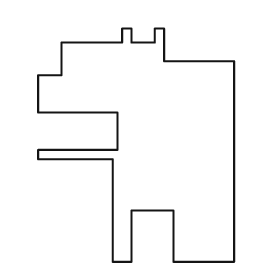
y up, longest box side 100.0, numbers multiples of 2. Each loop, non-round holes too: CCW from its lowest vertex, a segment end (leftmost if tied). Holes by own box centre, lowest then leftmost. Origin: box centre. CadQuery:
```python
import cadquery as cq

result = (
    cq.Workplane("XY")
    .moveTo(-10.0, -50.0)
    .lineTo(-2.0, -50.0)
    .lineTo(-2.0, -28.0)
    .lineTo(16.0, -28.0)
    .lineTo(16.0, -50.0)
    .lineTo(42.0, -50.0)
    .lineTo(42.0, 36.0)
    .lineTo(12.0, 36.0)
    .lineTo(12.0, 50.0)
    .lineTo(8.0, 50.0)
    .lineTo(8.0, 44.0)
    .lineTo(-2.0, 44.0)
    .lineTo(-2.0, 50.0)
    .lineTo(-6.0, 50.0)
    .lineTo(-6.0, 44.0)
    .lineTo(-32.0, 44.0)
    .lineTo(-32.0, 30.0)
    .lineTo(-42.0, 30.0)
    .lineTo(-42.0, 14.0)
    .lineTo(-8.0, 14.0)
    .lineTo(-8.0, -2.0)
    .lineTo(-42.0, -2.0)
    .lineTo(-42.0, -6.0)
    .lineTo(-10.0, -6.0)
    .close()
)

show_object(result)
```